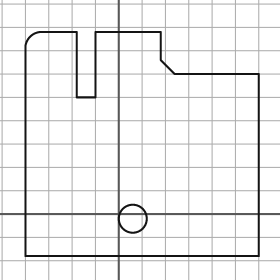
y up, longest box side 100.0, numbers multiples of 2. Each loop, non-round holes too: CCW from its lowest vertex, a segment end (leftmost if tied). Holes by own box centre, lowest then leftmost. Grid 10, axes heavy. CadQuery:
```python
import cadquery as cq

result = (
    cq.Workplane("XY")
    .moveTo(-40.0, -18.0)
    .lineTo(60.0, -18.0)
    .lineTo(60.0, 60.0)
    .lineTo(24.0, 60.0)
    .lineTo(18.0, 66.0)
    .lineTo(18.0, 78.0)
    .lineTo(-10.0, 78.0)
    .lineTo(-10.0, 50.0)
    .lineTo(-18.0, 50.0)
    .lineTo(-18.0, 78.0)
    .lineTo(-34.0, 78.0)
    .threePointArc((-38.0, 76.0), (-40.0, 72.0))
    .close()
    .moveTo(6.0, -2.0)
    .circle(6.0)
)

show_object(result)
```